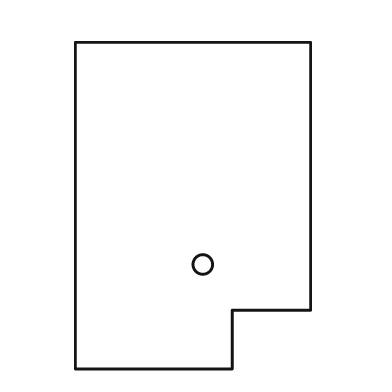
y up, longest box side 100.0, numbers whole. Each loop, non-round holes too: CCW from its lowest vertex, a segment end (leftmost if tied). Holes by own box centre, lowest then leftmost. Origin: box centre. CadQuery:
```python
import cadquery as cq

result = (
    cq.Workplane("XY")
    .moveTo(-36.0, -50.0)
    .lineTo(12.0, -50.0)
    .lineTo(12.0, -32.0)
    .lineTo(36.0, -32.0)
    .lineTo(36.0, 50.0)
    .lineTo(-36.0, 50.0)
    .close()
    .moveTo(3.0, -18.0)
    .circle(3.0)
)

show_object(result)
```